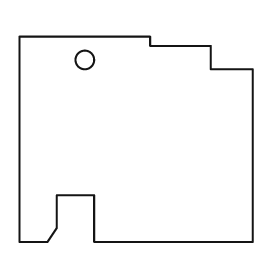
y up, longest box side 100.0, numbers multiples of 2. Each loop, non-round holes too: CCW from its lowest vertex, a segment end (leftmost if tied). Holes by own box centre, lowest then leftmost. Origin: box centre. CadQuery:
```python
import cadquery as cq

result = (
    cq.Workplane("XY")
    .moveTo(-50.0, -44.0)
    .lineTo(-38.0, -44.0)
    .lineTo(-34.0, -38.0)
    .lineTo(-34.0, -24.0)
    .lineTo(-18.0, -24.0)
    .lineTo(-18.0, -44.0)
    .lineTo(50.0, -44.0)
    .lineTo(50.0, 30.0)
    .lineTo(32.0, 30.0)
    .lineTo(32.0, 40.0)
    .lineTo(6.0, 40.0)
    .lineTo(6.0, 44.0)
    .lineTo(-50.0, 44.0)
    .close()
    .moveTo(-22.0, 34.0)
    .circle(4.0)
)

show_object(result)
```